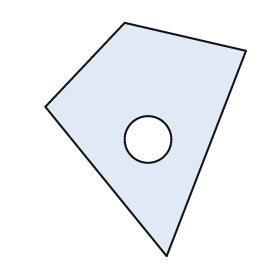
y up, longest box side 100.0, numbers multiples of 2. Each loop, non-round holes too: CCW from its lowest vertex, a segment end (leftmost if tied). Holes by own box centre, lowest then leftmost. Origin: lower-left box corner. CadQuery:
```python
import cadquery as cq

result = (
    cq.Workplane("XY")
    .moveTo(52.0, 0.0)
    .lineTo(86.0, 88.0)
    .lineTo(34.0, 100.0)
    .lineTo(0.0, 64.0)
    .close()
    .moveTo(44.0, 50.0)
    .circle(10.0)
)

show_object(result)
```